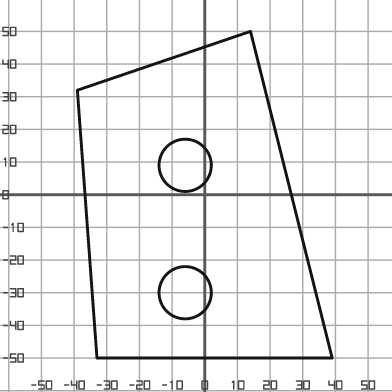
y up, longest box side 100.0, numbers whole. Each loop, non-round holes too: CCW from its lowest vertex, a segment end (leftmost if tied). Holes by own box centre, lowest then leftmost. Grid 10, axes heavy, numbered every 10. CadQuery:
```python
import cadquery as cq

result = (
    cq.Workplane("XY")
    .moveTo(-33.0, -50.0)
    .lineTo(39.0, -50.0)
    .lineTo(14.0, 50.0)
    .lineTo(-39.0, 32.0)
    .close()
    .moveTo(-6.0, -30.0)
    .circle(8.0)
    .moveTo(-6.0, 9.0)
    .circle(8.0)
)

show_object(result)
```